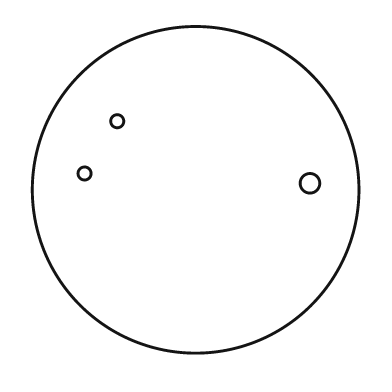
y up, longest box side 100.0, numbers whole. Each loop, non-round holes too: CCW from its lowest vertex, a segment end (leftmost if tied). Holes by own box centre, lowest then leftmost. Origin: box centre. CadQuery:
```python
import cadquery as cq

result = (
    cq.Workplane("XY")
    .moveTo(0.0, 0.0)
    .circle(50.0)
    .moveTo(35.0, 2.0)
    .circle(3.0)
    .moveTo(-34.0, 5.0)
    .circle(2.0)
    .moveTo(-24.0, 21.0)
    .circle(2.0)
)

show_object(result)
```